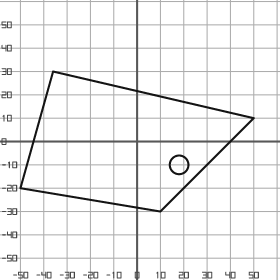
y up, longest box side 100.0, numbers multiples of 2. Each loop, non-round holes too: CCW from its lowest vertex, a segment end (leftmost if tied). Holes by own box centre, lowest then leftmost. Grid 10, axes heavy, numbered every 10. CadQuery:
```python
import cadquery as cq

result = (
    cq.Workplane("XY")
    .moveTo(10.0, -30.0)
    .lineTo(50.0, 10.0)
    .lineTo(-36.0, 30.0)
    .lineTo(-50.0, -20.0)
    .close()
    .moveTo(18.0, -10.0)
    .circle(4.0)
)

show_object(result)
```